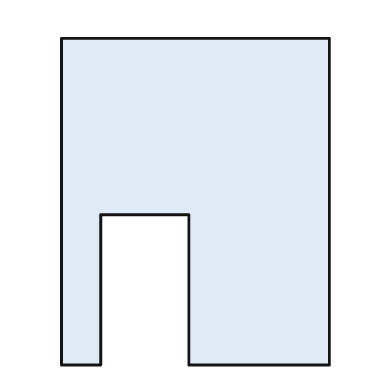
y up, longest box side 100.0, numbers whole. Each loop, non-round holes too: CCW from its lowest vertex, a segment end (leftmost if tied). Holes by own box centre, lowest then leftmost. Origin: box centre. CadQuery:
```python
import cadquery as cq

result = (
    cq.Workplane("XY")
    .moveTo(-41.0, -50.0)
    .lineTo(-29.0, -50.0)
    .lineTo(-29.0, -4.0)
    .lineTo(-2.0, -4.0)
    .lineTo(-2.0, -50.0)
    .lineTo(41.0, -50.0)
    .lineTo(41.0, 50.0)
    .lineTo(-41.0, 50.0)
    .close()
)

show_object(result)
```